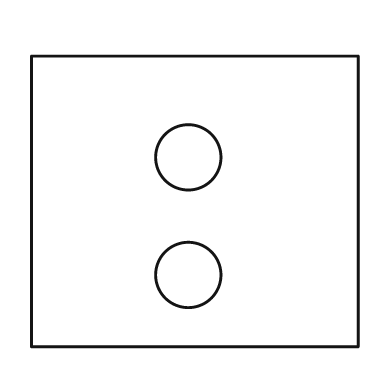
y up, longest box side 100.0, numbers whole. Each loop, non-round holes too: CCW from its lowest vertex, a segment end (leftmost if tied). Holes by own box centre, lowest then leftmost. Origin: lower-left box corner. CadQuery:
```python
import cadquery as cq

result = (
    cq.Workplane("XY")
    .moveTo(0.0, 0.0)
    .lineTo(100.0, 0.0)
    .lineTo(100.0, 89.0)
    .lineTo(0.0, 89.0)
    .close()
    .moveTo(48.0, 22.0)
    .circle(10.0)
    .moveTo(48.0, 58.0)
    .circle(10.0)
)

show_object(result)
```